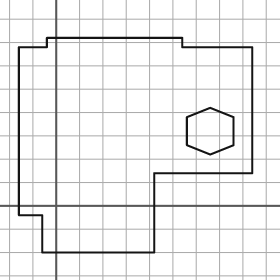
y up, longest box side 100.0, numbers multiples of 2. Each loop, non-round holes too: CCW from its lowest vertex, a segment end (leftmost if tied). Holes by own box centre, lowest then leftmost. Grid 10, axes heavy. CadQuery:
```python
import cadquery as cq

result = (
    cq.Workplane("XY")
    .moveTo(-6.0, -20.0)
    .lineTo(42.0, -20.0)
    .lineTo(42.0, 14.0)
    .lineTo(84.0, 14.0)
    .lineTo(84.0, 68.0)
    .lineTo(54.0, 68.0)
    .lineTo(54.0, 72.0)
    .lineTo(-4.0, 72.0)
    .lineTo(-4.0, 68.0)
    .lineTo(-16.0, 68.0)
    .lineTo(-16.0, -4.0)
    .lineTo(-6.0, -4.0)
    .close()
    .moveTo(66.0, 22.0)
    .lineTo(76.0, 26.0)
    .lineTo(76.0, 38.0)
    .lineTo(66.0, 42.0)
    .lineTo(56.0, 38.0)
    .lineTo(56.0, 26.0)
    .close()
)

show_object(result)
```